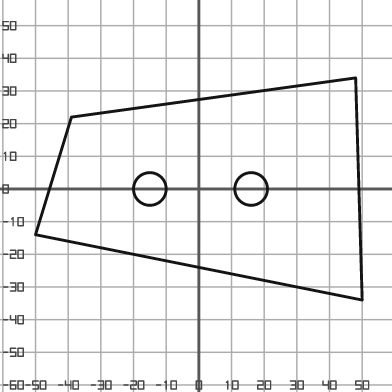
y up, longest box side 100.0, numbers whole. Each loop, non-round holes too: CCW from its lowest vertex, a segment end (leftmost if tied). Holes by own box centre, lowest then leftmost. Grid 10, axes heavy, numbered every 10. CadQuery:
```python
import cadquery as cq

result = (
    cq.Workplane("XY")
    .moveTo(50.0, -34.0)
    .lineTo(48.0, 34.0)
    .lineTo(-39.0, 22.0)
    .lineTo(-50.0, -14.0)
    .close()
    .moveTo(-15.0, 0.0)
    .circle(5.0)
    .moveTo(16.0, 0.0)
    .circle(5.0)
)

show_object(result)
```